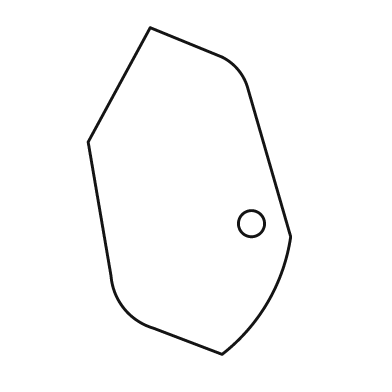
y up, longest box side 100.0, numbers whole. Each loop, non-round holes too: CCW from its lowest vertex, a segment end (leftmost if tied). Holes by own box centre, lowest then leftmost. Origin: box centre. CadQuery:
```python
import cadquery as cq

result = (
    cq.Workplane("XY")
    .moveTo(10.0, -50.0)
    .threePointArc((24.0, -34.0), (31.0, -14.0))
    .lineTo(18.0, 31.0)
    .threePointArc((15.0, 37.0), (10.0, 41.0))
    .lineTo(-12.0, 50.0)
    .lineTo(-31.0, 15.0)
    .lineTo(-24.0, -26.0)
    .threePointArc((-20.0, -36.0), (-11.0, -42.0))
    .close()
    .moveTo(19.0, -10.0)
    .circle(4.0)
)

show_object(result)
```